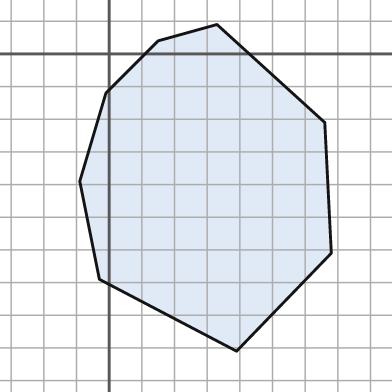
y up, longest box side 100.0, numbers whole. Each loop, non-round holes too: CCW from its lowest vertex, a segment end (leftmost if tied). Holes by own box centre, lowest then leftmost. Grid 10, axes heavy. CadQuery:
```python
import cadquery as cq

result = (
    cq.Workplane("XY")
    .moveTo(39.0, -91.0)
    .lineTo(68.0, -61.0)
    .lineTo(66.0, -21.0)
    .lineTo(33.0, 9.0)
    .lineTo(15.0, 4.0)
    .lineTo(-1.0, -12.0)
    .lineTo(-9.0, -39.0)
    .lineTo(-3.0, -69.0)
    .close()
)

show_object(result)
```